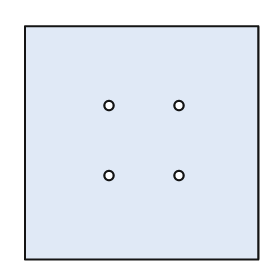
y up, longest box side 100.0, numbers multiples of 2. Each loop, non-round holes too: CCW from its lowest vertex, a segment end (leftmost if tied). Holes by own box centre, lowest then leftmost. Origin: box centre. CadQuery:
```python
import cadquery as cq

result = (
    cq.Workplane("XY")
    .moveTo(-50.0, -50.0)
    .lineTo(50.0, -50.0)
    .lineTo(50.0, 50.0)
    .lineTo(-50.0, 50.0)
    .close()
    .moveTo(-14.0, -14.0)
    .circle(2.0)
    .moveTo(16.0, -14.0)
    .circle(2.0)
    .moveTo(-14.0, 16.0)
    .circle(2.0)
    .moveTo(16.0, 16.0)
    .circle(2.0)
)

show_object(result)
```